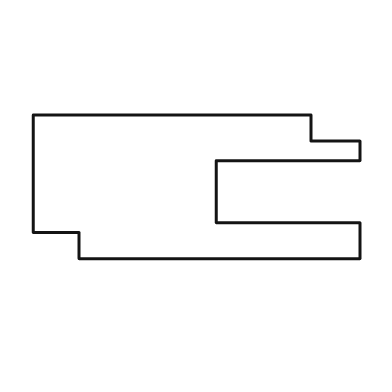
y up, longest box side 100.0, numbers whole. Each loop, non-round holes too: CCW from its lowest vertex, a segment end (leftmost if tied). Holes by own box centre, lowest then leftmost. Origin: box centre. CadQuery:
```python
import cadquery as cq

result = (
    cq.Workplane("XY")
    .moveTo(-36.0, -22.0)
    .lineTo(50.0, -22.0)
    .lineTo(50.0, -11.0)
    .lineTo(6.0, -11.0)
    .lineTo(6.0, 8.0)
    .lineTo(50.0, 8.0)
    .lineTo(50.0, 14.0)
    .lineTo(35.0, 14.0)
    .lineTo(35.0, 22.0)
    .lineTo(-50.0, 22.0)
    .lineTo(-50.0, -14.0)
    .lineTo(-36.0, -14.0)
    .close()
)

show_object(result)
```